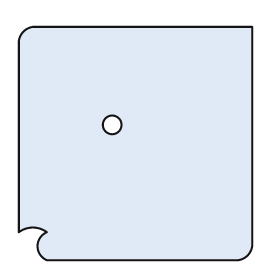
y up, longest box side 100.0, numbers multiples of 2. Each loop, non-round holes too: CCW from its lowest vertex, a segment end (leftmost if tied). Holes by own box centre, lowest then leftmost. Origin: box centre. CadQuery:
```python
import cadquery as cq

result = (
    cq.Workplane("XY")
    .moveTo(-38.0, -50.0)
    .lineTo(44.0, -50.0)
    .threePointArc((48.0, -48.0), (50.0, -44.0))
    .lineTo(50.0, 50.0)
    .lineTo(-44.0, 50.0)
    .threePointArc((-48.0, 48.0), (-50.0, 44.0))
    .lineTo(-50.0, -38.0)
    .threePointArc((-44.0, -36.0), (-38.0, -38.0))
    .threePointArc((-42.0, -44.0), (-38.0, -50.0))
    .close()
    .moveTo(-10.0, 8.0)
    .circle(4.0)
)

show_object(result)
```